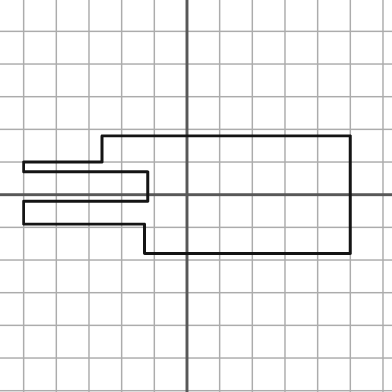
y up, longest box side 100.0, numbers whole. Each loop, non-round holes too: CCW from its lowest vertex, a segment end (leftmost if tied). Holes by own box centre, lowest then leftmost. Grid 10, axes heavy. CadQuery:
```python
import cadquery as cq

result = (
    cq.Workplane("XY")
    .moveTo(-13.0, -18.0)
    .lineTo(50.0, -18.0)
    .lineTo(50.0, 18.0)
    .lineTo(-26.0, 18.0)
    .lineTo(-26.0, 10.0)
    .lineTo(-50.0, 10.0)
    .lineTo(-50.0, 7.0)
    .lineTo(-12.0, 7.0)
    .lineTo(-12.0, -2.0)
    .lineTo(-50.0, -2.0)
    .lineTo(-50.0, -9.0)
    .lineTo(-13.0, -9.0)
    .close()
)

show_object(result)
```